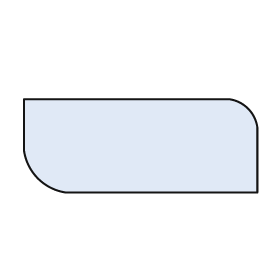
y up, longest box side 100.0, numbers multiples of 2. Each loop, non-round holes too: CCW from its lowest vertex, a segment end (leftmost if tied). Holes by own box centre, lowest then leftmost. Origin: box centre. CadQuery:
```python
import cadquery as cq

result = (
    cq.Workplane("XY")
    .moveTo(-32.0, -20.0)
    .lineTo(50.0, -20.0)
    .lineTo(50.0, 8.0)
    .threePointArc((46.0, 16.0), (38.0, 20.0))
    .lineTo(-50.0, 20.0)
    .lineTo(-50.0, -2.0)
    .threePointArc((-44.0, -14.0), (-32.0, -20.0))
    .close()
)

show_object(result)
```